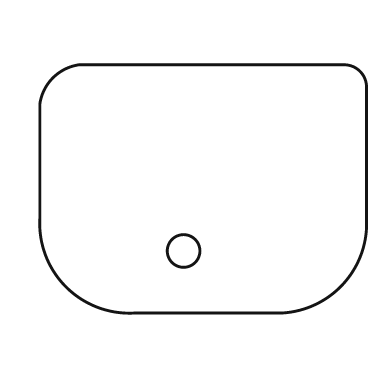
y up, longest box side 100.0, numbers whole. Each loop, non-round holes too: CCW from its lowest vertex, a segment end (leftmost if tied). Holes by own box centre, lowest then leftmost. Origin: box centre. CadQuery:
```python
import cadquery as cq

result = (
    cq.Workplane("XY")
    .moveTo(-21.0, -38.0)
    .lineTo(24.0, -38.0)
    .threePointArc((42.0, -30.0), (50.0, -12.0))
    .lineTo(50.0, 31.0)
    .threePointArc((48.0, 36.0), (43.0, 38.0))
    .lineTo(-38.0, 38.0)
    .threePointArc((-46.0, 34.0), (-50.0, 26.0))
    .lineTo(-50.0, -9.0)
    .threePointArc((-42.0, -30.0), (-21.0, -38.0))
    .close()
    .moveTo(-6.0, -19.0)
    .circle(5.0)
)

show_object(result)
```